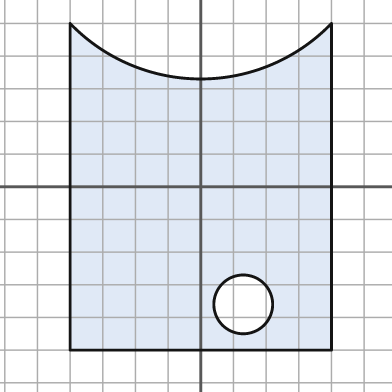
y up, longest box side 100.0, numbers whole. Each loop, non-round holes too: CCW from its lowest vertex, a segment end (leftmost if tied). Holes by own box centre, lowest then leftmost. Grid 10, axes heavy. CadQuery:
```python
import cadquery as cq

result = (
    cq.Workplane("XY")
    .moveTo(-40.0, -50.0)
    .lineTo(40.0, -50.0)
    .lineTo(40.0, 50.0)
    .threePointArc((0.0, 33.0), (-40.0, 50.0))
    .close()
    .moveTo(13.0, -36.0)
    .circle(9.0)
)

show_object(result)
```